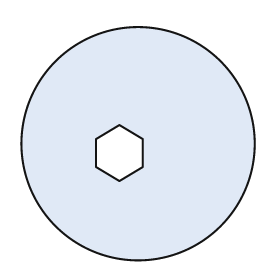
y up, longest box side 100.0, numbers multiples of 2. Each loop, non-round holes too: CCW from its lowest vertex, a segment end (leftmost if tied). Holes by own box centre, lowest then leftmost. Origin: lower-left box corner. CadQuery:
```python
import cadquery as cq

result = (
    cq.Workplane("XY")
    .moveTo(50.0, 50.0)
    .circle(50.0)
    .moveTo(42.0, 34.0)
    .lineTo(52.0, 40.0)
    .lineTo(52.0, 52.0)
    .lineTo(42.0, 58.0)
    .lineTo(32.0, 52.0)
    .lineTo(32.0, 40.0)
    .close()
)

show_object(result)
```